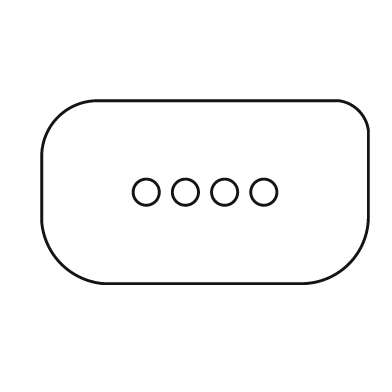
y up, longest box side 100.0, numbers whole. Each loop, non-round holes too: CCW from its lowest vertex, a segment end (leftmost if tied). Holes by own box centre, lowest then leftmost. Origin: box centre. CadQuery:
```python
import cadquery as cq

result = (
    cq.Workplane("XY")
    .moveTo(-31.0, -28.0)
    .lineTo(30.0, -28.0)
    .threePointArc((44.0, -22.0), (50.0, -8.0))
    .lineTo(50.0, 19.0)
    .threePointArc((47.0, 25.0), (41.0, 28.0))
    .lineTo(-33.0, 28.0)
    .threePointArc((-45.0, 23.0), (-50.0, 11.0))
    .lineTo(-50.0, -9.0)
    .threePointArc((-44.0, -22.0), (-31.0, -28.0))
    .close()
    .moveTo(-18.0, 0.0)
    .circle(4.0)
    .moveTo(-6.0, 0.0)
    .circle(4.0)
    .moveTo(6.0, 0.0)
    .circle(4.0)
    .moveTo(18.0, 0.0)
    .circle(4.0)
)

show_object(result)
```